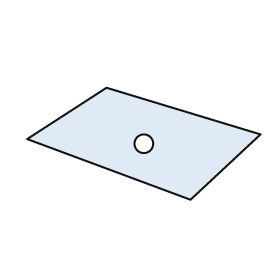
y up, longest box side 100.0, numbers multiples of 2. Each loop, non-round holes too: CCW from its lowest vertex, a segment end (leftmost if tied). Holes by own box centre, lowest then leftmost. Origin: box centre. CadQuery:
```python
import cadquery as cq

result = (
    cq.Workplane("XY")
    .moveTo(20.0, -24.0)
    .lineTo(50.0, 4.0)
    .lineTo(-16.0, 24.0)
    .lineTo(-50.0, 2.0)
    .close()
    .moveTo(0.0, 0.0)
    .circle(4.0)
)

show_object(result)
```